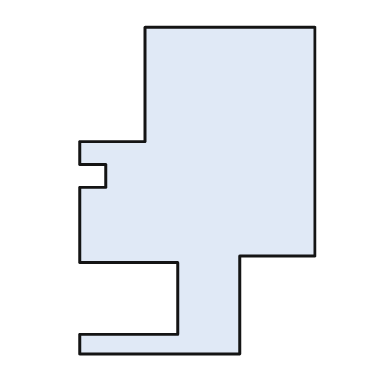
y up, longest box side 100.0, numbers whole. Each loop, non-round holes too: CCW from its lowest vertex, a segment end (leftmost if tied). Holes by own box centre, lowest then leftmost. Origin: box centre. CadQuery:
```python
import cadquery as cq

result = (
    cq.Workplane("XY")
    .moveTo(-36.0, -50.0)
    .lineTo(13.0, -50.0)
    .lineTo(13.0, -20.0)
    .lineTo(36.0, -20.0)
    .lineTo(36.0, 50.0)
    .lineTo(-16.0, 50.0)
    .lineTo(-16.0, 15.0)
    .lineTo(-36.0, 15.0)
    .lineTo(-36.0, 8.0)
    .lineTo(-28.0, 8.0)
    .lineTo(-28.0, 1.0)
    .lineTo(-36.0, 1.0)
    .lineTo(-36.0, -22.0)
    .lineTo(-6.0, -22.0)
    .lineTo(-6.0, -44.0)
    .lineTo(-36.0, -44.0)
    .close()
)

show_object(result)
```